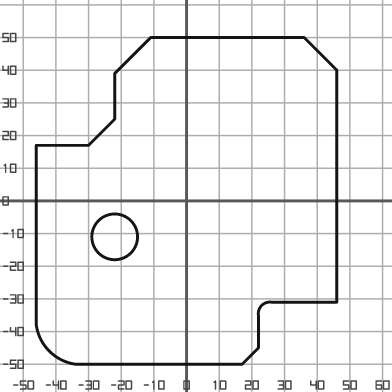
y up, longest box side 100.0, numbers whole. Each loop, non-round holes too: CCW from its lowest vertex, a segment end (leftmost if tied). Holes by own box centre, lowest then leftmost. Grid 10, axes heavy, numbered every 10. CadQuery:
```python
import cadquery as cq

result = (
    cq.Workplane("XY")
    .moveTo(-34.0, -50.0)
    .lineTo(17.0, -50.0)
    .lineTo(22.0, -45.0)
    .lineTo(22.0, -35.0)
    .threePointArc((23.0, -32.0), (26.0, -31.0))
    .lineTo(46.0, -31.0)
    .lineTo(46.0, 40.0)
    .lineTo(36.0, 50.0)
    .lineTo(-11.0, 50.0)
    .lineTo(-22.0, 39.0)
    .lineTo(-22.0, 25.0)
    .lineTo(-30.0, 17.0)
    .lineTo(-46.0, 17.0)
    .lineTo(-46.0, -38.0)
    .threePointArc((-42.0, -46.0), (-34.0, -50.0))
    .close()
    .moveTo(-22.0, -11.0)
    .circle(7.0)
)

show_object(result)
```